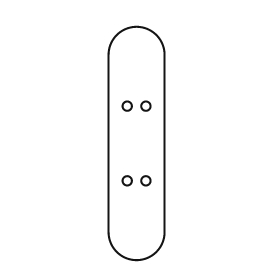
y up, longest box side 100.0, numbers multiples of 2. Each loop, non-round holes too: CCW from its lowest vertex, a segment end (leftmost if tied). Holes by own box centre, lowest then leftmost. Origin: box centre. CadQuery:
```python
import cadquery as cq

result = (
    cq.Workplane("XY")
    .moveTo(-12.0, -38.0)
    .threePointArc((0.0, -50.0), (12.0, -38.0))
    .lineTo(12.0, 38.0)
    .threePointArc((0.0, 50.0), (-12.0, 38.0))
    .close()
    .moveTo(-4.0, -16.0)
    .circle(2.0)
    .moveTo(4.0, -16.0)
    .circle(2.0)
    .moveTo(-4.0, 16.0)
    .circle(2.0)
    .moveTo(4.0, 16.0)
    .circle(2.0)
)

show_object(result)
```